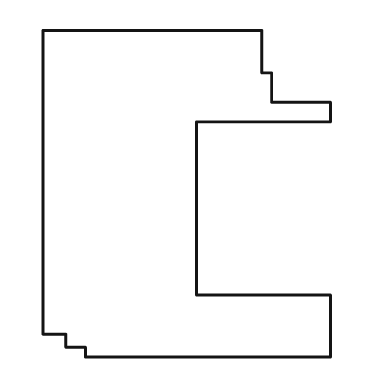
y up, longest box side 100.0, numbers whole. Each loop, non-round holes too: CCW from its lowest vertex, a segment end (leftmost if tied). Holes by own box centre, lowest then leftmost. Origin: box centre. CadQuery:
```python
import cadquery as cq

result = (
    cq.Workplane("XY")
    .moveTo(-31.0, -50.0)
    .lineTo(44.0, -50.0)
    .lineTo(44.0, -31.0)
    .lineTo(3.0, -31.0)
    .lineTo(3.0, 22.0)
    .lineTo(44.0, 22.0)
    .lineTo(44.0, 28.0)
    .lineTo(26.0, 28.0)
    .lineTo(26.0, 37.0)
    .lineTo(23.0, 37.0)
    .lineTo(23.0, 50.0)
    .lineTo(-44.0, 50.0)
    .lineTo(-44.0, -43.0)
    .lineTo(-37.0, -43.0)
    .lineTo(-37.0, -47.0)
    .lineTo(-31.0, -47.0)
    .close()
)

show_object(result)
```